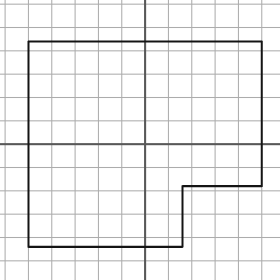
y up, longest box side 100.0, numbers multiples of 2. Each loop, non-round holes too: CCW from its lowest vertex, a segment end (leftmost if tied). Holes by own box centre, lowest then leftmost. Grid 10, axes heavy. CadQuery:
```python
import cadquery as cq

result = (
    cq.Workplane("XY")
    .moveTo(-50.0, -44.0)
    .lineTo(16.0, -44.0)
    .lineTo(16.0, -18.0)
    .lineTo(50.0, -18.0)
    .lineTo(50.0, 44.0)
    .lineTo(-50.0, 44.0)
    .close()
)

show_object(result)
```